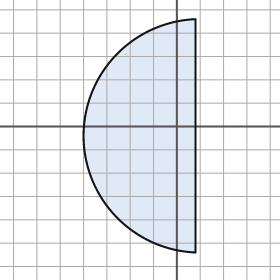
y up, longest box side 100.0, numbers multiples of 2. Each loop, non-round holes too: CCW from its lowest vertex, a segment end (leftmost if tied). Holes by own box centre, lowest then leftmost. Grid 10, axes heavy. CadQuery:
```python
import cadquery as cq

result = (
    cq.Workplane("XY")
    .moveTo(8.0, -54.0)
    .lineTo(8.0, 46.0)
    .threePointArc((-40.0, -4.0), (8.0, -54.0))
    .close()
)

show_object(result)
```